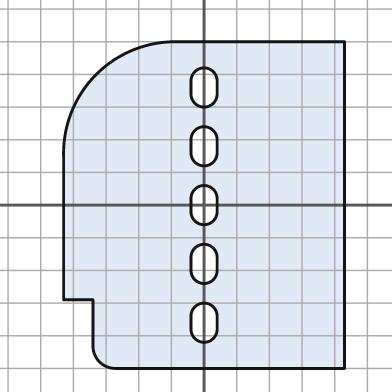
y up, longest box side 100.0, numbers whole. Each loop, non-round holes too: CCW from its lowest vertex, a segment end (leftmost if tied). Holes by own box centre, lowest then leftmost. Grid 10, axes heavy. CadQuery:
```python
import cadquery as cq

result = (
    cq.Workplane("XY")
    .moveTo(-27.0, -50.0)
    .lineTo(43.0, -50.0)
    .lineTo(43.0, 50.0)
    .lineTo(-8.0, 50.0)
    .threePointArc((-33.0, 40.0), (-43.0, 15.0))
    .lineTo(-43.0, -29.0)
    .lineTo(-34.0, -29.0)
    .lineTo(-34.0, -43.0)
    .threePointArc((-32.0, -48.0), (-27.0, -50.0))
    .close()
    .moveTo(-4.0, -38.0)
    .threePointArc((0.0, -42.0), (4.0, -38.0))
    .lineTo(4.0, -34.0)
    .threePointArc((0.0, -30.0), (-4.0, -34.0))
    .close()
    .moveTo(-4.0, -20.0)
    .threePointArc((0.0, -24.0), (4.0, -20.0))
    .lineTo(4.0, -16.0)
    .threePointArc((0.0, -12.0), (-4.0, -16.0))
    .close()
    .moveTo(-4.0, -2.0)
    .threePointArc((0.0, -6.0), (4.0, -2.0))
    .lineTo(4.0, 2.0)
    .threePointArc((0.0, 6.0), (-4.0, 2.0))
    .close()
    .moveTo(-4.0, 16.0)
    .threePointArc((0.0, 12.0), (4.0, 16.0))
    .lineTo(4.0, 20.0)
    .threePointArc((0.0, 24.0), (-4.0, 20.0))
    .close()
    .moveTo(-4.0, 34.0)
    .threePointArc((0.0, 30.0), (4.0, 34.0))
    .lineTo(4.0, 38.0)
    .threePointArc((0.0, 42.0), (-4.0, 38.0))
    .close()
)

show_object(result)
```